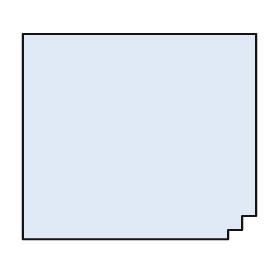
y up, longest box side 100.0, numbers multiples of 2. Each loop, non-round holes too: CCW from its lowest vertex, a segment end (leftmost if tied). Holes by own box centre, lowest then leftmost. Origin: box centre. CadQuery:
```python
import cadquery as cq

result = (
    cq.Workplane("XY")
    .moveTo(-50.0, -44.0)
    .lineTo(38.0, -44.0)
    .lineTo(38.0, -40.0)
    .lineTo(44.0, -40.0)
    .lineTo(44.0, -34.0)
    .lineTo(50.0, -34.0)
    .lineTo(50.0, 44.0)
    .lineTo(-50.0, 44.0)
    .close()
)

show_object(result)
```